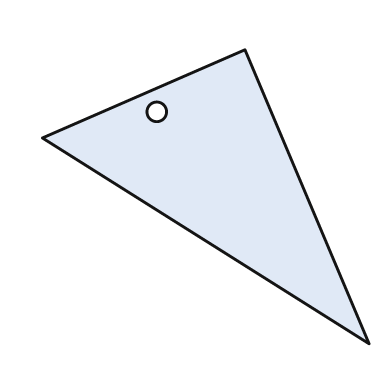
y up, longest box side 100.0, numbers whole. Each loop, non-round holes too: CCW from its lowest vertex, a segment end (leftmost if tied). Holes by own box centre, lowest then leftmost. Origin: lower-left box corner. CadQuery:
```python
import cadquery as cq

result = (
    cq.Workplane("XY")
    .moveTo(100.0, 0.0)
    .lineTo(62.0, 90.0)
    .lineTo(0.0, 63.0)
    .close()
    .moveTo(35.0, 71.0)
    .circle(3.0)
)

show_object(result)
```